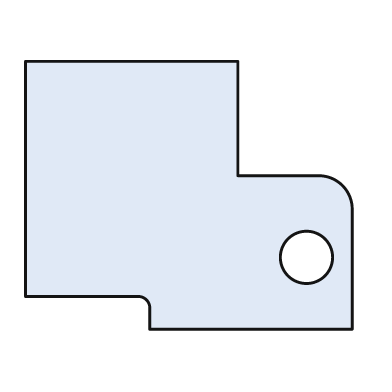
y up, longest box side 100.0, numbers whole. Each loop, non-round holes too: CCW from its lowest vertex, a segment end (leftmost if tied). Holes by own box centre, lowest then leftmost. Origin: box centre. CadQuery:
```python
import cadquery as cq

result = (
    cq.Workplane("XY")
    .moveTo(-12.0, -41.0)
    .lineTo(50.0, -41.0)
    .lineTo(50.0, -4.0)
    .threePointArc((47.0, 3.0), (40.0, 6.0))
    .lineTo(15.0, 6.0)
    .lineTo(15.0, 41.0)
    .lineTo(-50.0, 41.0)
    .lineTo(-50.0, -31.0)
    .lineTo(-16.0, -31.0)
    .threePointArc((-13.0, -32.0), (-12.0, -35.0))
    .close()
    .moveTo(36.0, -19.0)
    .circle(8.0)
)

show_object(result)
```